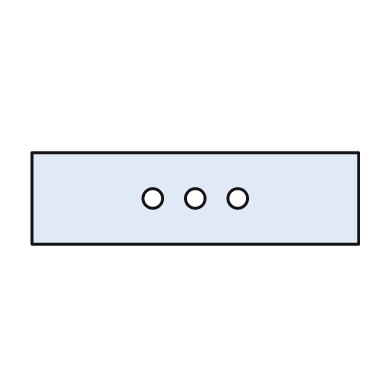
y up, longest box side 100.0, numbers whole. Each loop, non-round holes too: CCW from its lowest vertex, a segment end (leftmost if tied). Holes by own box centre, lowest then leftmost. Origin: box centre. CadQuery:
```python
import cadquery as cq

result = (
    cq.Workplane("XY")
    .moveTo(-50.0, -14.0)
    .lineTo(50.0, -14.0)
    .lineTo(50.0, 14.0)
    .lineTo(-50.0, 14.0)
    .close()
    .moveTo(-13.0, 0.0)
    .circle(3.0)
    .moveTo(0.0, 0.0)
    .circle(3.0)
    .moveTo(13.0, 0.0)
    .circle(3.0)
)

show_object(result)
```